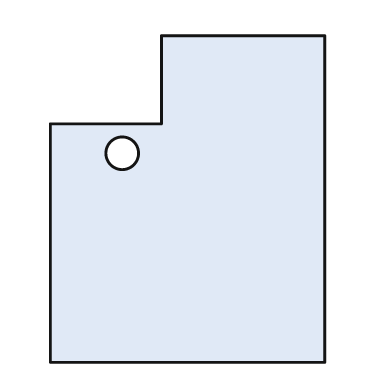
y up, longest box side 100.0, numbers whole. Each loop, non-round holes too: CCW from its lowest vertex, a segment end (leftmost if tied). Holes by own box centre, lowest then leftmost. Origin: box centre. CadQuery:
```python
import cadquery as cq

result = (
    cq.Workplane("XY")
    .moveTo(-42.0, -50.0)
    .lineTo(42.0, -50.0)
    .lineTo(42.0, 50.0)
    .lineTo(-8.0, 50.0)
    .lineTo(-8.0, 23.0)
    .lineTo(-42.0, 23.0)
    .close()
    .moveTo(-20.0, 14.0)
    .circle(5.0)
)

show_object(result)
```